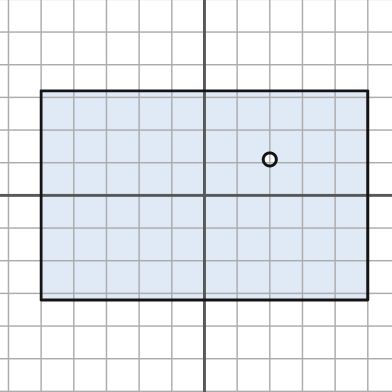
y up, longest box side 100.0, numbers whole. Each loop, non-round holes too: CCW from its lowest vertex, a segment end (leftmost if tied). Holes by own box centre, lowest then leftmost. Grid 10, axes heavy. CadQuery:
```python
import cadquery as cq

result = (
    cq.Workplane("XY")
    .moveTo(-50.0, -32.0)
    .lineTo(50.0, -32.0)
    .lineTo(50.0, 32.0)
    .lineTo(-50.0, 32.0)
    .close()
    .moveTo(20.0, 11.0)
    .circle(2.0)
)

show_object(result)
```